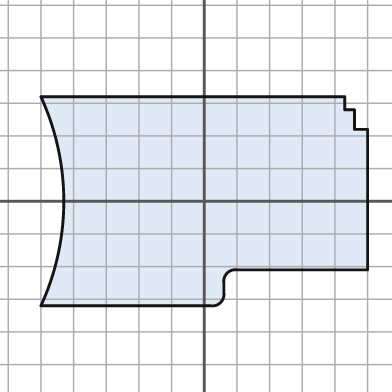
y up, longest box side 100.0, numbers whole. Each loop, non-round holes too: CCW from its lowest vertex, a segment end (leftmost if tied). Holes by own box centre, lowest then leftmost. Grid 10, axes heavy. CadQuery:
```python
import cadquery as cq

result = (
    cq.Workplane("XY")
    .moveTo(-50.0, -32.0)
    .lineTo(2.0, -32.0)
    .threePointArc((5.0, -31.0), (6.0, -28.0))
    .lineTo(6.0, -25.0)
    .threePointArc((7.0, -22.0), (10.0, -21.0))
    .lineTo(50.0, -21.0)
    .lineTo(50.0, 22.0)
    .lineTo(46.0, 22.0)
    .lineTo(46.0, 28.0)
    .lineTo(43.0, 28.0)
    .lineTo(43.0, 32.0)
    .lineTo(-50.0, 32.0)
    .threePointArc((-43.0, 0.0), (-50.0, -32.0))
    .close()
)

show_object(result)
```